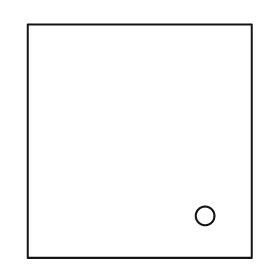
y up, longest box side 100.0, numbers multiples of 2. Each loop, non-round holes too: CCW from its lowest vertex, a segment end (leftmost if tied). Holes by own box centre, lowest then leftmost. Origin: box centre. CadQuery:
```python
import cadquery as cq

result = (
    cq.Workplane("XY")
    .moveTo(-48.0, -50.0)
    .lineTo(48.0, -50.0)
    .lineTo(48.0, 50.0)
    .lineTo(-48.0, 50.0)
    .close()
    .moveTo(28.0, -32.0)
    .circle(4.0)
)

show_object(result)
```